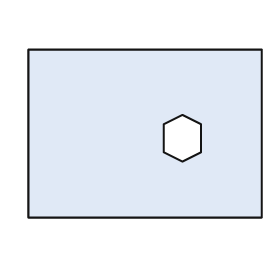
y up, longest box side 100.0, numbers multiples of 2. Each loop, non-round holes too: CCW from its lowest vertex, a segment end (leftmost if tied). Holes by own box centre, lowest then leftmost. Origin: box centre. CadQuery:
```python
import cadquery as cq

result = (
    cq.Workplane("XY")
    .moveTo(-50.0, -36.0)
    .lineTo(50.0, -36.0)
    .lineTo(50.0, 36.0)
    .lineTo(-50.0, 36.0)
    .close()
    .moveTo(16.0, -12.0)
    .lineTo(24.0, -8.0)
    .lineTo(24.0, 4.0)
    .lineTo(16.0, 8.0)
    .lineTo(8.0, 4.0)
    .lineTo(8.0, -8.0)
    .close()
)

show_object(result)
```